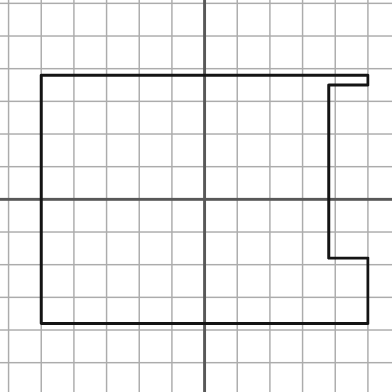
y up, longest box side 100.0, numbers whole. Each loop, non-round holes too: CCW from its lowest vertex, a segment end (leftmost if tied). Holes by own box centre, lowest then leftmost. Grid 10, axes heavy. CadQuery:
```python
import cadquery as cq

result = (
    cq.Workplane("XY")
    .moveTo(-50.0, -38.0)
    .lineTo(50.0, -38.0)
    .lineTo(50.0, -18.0)
    .lineTo(38.0, -18.0)
    .lineTo(38.0, 35.0)
    .lineTo(50.0, 35.0)
    .lineTo(50.0, 38.0)
    .lineTo(-50.0, 38.0)
    .close()
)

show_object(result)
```